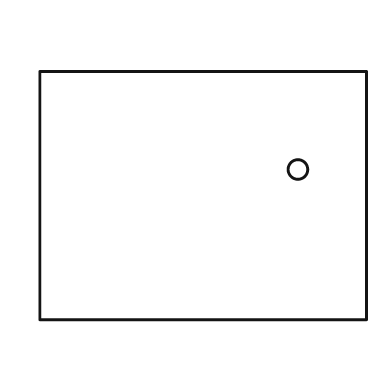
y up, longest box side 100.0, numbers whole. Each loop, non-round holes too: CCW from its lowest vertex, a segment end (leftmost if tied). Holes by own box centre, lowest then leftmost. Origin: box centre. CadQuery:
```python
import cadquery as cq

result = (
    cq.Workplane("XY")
    .moveTo(-50.0, -38.0)
    .lineTo(50.0, -38.0)
    .lineTo(50.0, 38.0)
    .lineTo(-50.0, 38.0)
    .close()
    .moveTo(29.0, 8.0)
    .circle(3.0)
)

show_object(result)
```